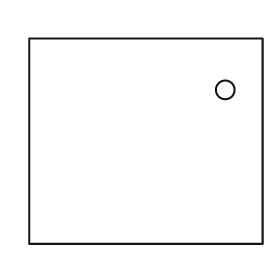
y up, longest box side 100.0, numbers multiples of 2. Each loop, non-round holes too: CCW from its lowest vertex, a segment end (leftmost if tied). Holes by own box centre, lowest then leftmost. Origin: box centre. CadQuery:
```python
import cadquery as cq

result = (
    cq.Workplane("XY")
    .moveTo(-50.0, -44.0)
    .lineTo(50.0, -44.0)
    .lineTo(50.0, 44.0)
    .lineTo(-50.0, 44.0)
    .close()
    .moveTo(34.0, 22.0)
    .circle(4.0)
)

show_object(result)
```